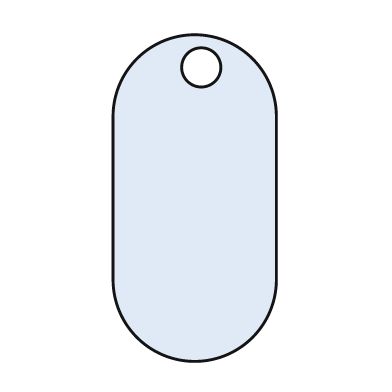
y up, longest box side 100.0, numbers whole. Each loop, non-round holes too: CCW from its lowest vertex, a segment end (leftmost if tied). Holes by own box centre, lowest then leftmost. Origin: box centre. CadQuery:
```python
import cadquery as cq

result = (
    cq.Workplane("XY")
    .moveTo(-25.0, -25.0)
    .threePointArc((0.0, -50.0), (25.0, -25.0))
    .lineTo(25.0, 25.0)
    .threePointArc((0.0, 50.0), (-25.0, 25.0))
    .close()
    .moveTo(2.0, 40.0)
    .circle(6.0)
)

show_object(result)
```